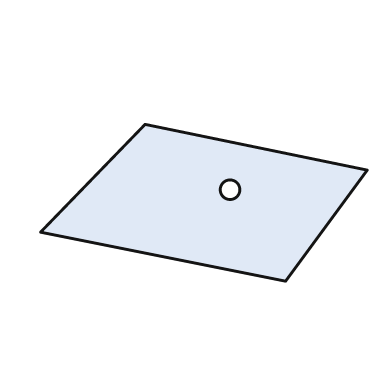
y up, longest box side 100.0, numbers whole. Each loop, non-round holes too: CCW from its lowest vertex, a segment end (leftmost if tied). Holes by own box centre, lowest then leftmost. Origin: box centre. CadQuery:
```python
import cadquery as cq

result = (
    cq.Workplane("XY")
    .moveTo(25.0, -24.0)
    .lineTo(50.0, 10.0)
    .lineTo(-18.0, 24.0)
    .lineTo(-50.0, -9.0)
    .close()
    .moveTo(8.0, 4.0)
    .circle(3.0)
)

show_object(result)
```